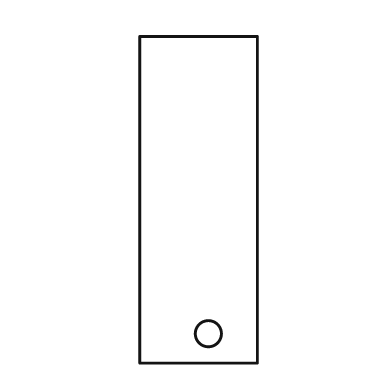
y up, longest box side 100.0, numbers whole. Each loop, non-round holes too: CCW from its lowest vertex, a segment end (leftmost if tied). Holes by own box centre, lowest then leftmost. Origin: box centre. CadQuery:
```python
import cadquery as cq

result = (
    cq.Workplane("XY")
    .moveTo(-18.0, -50.0)
    .lineTo(18.0, -50.0)
    .lineTo(18.0, 50.0)
    .lineTo(-18.0, 50.0)
    .close()
    .moveTo(3.0, -41.0)
    .circle(4.0)
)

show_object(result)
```